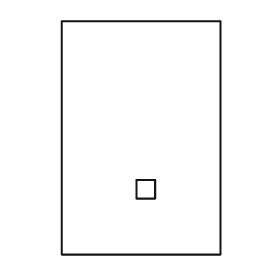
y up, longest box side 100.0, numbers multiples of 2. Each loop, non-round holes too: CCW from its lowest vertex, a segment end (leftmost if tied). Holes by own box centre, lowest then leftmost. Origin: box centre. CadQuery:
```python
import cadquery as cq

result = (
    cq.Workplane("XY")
    .moveTo(-34.0, -50.0)
    .lineTo(34.0, -50.0)
    .lineTo(34.0, 50.0)
    .lineTo(-34.0, 50.0)
    .close()
    .moveTo(-2.0, -26.0)
    .lineTo(6.0, -26.0)
    .lineTo(6.0, -18.0)
    .lineTo(-2.0, -18.0)
    .close()
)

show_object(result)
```